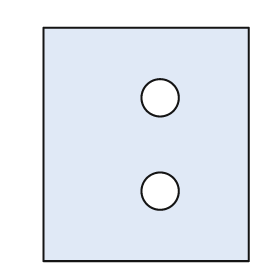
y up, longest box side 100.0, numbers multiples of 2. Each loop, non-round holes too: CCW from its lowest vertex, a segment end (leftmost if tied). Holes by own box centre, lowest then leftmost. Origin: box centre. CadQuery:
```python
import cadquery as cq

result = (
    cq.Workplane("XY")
    .moveTo(-44.0, -50.0)
    .lineTo(44.0, -50.0)
    .lineTo(44.0, 50.0)
    .lineTo(-44.0, 50.0)
    .close()
    .moveTo(6.0, -20.0)
    .circle(8.0)
    .moveTo(6.0, 20.0)
    .circle(8.0)
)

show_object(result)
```